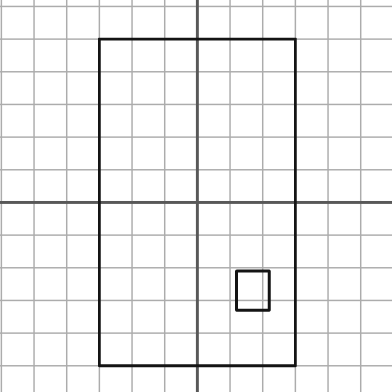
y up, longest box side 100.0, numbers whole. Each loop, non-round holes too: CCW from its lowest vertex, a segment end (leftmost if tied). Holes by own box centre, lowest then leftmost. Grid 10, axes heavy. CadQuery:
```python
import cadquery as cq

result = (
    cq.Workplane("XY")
    .moveTo(-30.0, -50.0)
    .lineTo(30.0, -50.0)
    .lineTo(30.0, 50.0)
    .lineTo(-30.0, 50.0)
    .close()
    .moveTo(12.0, -33.0)
    .lineTo(22.0, -33.0)
    .lineTo(22.0, -21.0)
    .lineTo(12.0, -21.0)
    .close()
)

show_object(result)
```